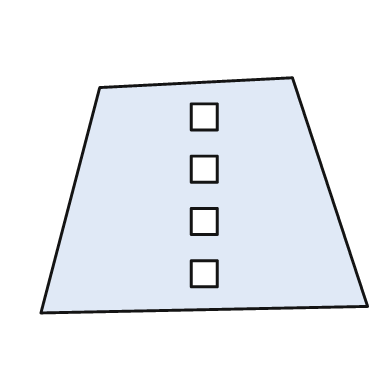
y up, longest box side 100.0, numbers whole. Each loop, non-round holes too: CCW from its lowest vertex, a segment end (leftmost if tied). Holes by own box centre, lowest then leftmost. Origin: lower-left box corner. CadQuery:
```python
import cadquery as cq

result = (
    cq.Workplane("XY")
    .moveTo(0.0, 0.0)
    .lineTo(100.0, 2.0)
    .lineTo(77.0, 72.0)
    .lineTo(18.0, 69.0)
    .close()
    .moveTo(46.0, 8.0)
    .lineTo(54.0, 8.0)
    .lineTo(54.0, 16.0)
    .lineTo(46.0, 16.0)
    .close()
    .moveTo(46.0, 24.0)
    .lineTo(54.0, 24.0)
    .lineTo(54.0, 32.0)
    .lineTo(46.0, 32.0)
    .close()
    .moveTo(46.0, 40.0)
    .lineTo(54.0, 40.0)
    .lineTo(54.0, 48.0)
    .lineTo(46.0, 48.0)
    .close()
    .moveTo(46.0, 56.0)
    .lineTo(54.0, 56.0)
    .lineTo(54.0, 64.0)
    .lineTo(46.0, 64.0)
    .close()
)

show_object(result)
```